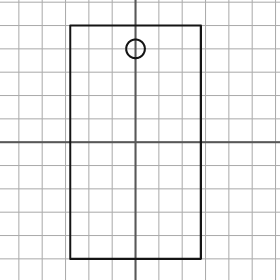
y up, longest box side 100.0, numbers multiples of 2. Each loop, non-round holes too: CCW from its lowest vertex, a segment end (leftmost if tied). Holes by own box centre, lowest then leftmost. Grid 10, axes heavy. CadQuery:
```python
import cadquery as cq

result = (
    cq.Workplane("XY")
    .moveTo(-28.0, -50.0)
    .lineTo(28.0, -50.0)
    .lineTo(28.0, 50.0)
    .lineTo(-28.0, 50.0)
    .close()
    .moveTo(0.0, 40.0)
    .circle(4.0)
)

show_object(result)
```